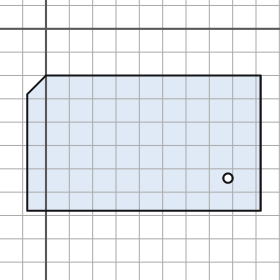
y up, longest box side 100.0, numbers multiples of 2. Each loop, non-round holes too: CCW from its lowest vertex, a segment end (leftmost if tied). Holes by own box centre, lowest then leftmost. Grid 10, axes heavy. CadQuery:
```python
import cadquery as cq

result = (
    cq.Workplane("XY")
    .moveTo(-8.0, -78.0)
    .lineTo(92.0, -78.0)
    .lineTo(92.0, -20.0)
    .lineTo(0.0, -20.0)
    .lineTo(-8.0, -28.0)
    .close()
    .moveTo(78.0, -64.0)
    .circle(2.0)
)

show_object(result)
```